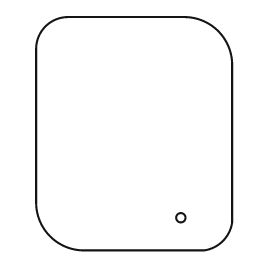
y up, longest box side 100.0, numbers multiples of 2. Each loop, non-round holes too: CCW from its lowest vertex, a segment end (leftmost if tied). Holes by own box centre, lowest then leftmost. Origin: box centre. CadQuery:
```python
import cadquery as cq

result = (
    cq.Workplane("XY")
    .moveTo(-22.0, -50.0)
    .lineTo(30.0, -50.0)
    .threePointArc((38.0, -46.0), (42.0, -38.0))
    .lineTo(42.0, 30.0)
    .threePointArc((36.0, 44.0), (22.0, 50.0))
    .lineTo(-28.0, 50.0)
    .threePointArc((-38.0, 46.0), (-42.0, 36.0))
    .lineTo(-42.0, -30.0)
    .threePointArc((-36.0, -44.0), (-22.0, -50.0))
    .close()
    .moveTo(20.0, -36.0)
    .circle(2.0)
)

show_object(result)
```